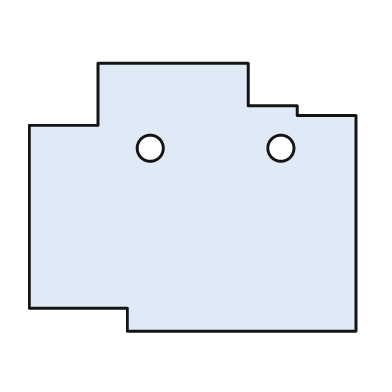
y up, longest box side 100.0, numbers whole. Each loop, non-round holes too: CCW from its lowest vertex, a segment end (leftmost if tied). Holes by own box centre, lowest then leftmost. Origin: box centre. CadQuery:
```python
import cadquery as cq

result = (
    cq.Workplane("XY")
    .moveTo(-20.0, -41.0)
    .lineTo(50.0, -41.0)
    .lineTo(50.0, 25.0)
    .lineTo(32.0, 25.0)
    .lineTo(32.0, 28.0)
    .lineTo(17.0, 28.0)
    .lineTo(17.0, 41.0)
    .lineTo(-29.0, 41.0)
    .lineTo(-29.0, 22.0)
    .lineTo(-50.0, 22.0)
    .lineTo(-50.0, -34.0)
    .lineTo(-20.0, -34.0)
    .close()
    .moveTo(-13.0, 15.0)
    .circle(4.0)
    .moveTo(27.0, 15.0)
    .circle(4.0)
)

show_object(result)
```